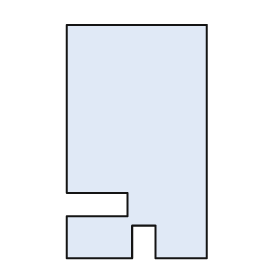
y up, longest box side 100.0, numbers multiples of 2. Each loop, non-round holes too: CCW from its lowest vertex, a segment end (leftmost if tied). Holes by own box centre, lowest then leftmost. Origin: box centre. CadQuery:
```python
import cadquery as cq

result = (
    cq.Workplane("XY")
    .moveTo(-30.0, -50.0)
    .lineTo(-2.0, -50.0)
    .lineTo(-2.0, -36.0)
    .lineTo(8.0, -36.0)
    .lineTo(8.0, -50.0)
    .lineTo(30.0, -50.0)
    .lineTo(30.0, 50.0)
    .lineTo(-30.0, 50.0)
    .lineTo(-30.0, -22.0)
    .lineTo(-4.0, -22.0)
    .lineTo(-4.0, -32.0)
    .lineTo(-30.0, -32.0)
    .close()
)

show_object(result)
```